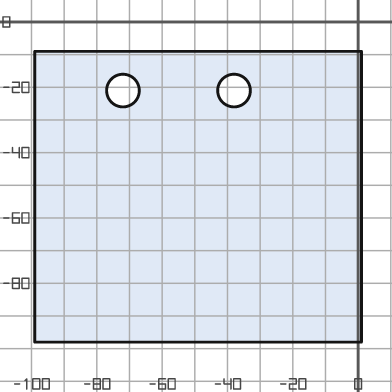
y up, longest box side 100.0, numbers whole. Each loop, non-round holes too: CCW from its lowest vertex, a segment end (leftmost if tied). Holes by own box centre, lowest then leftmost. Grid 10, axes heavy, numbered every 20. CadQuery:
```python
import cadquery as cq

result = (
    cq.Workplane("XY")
    .moveTo(-99.0, -98.0)
    .lineTo(1.0, -98.0)
    .lineTo(1.0, -9.0)
    .lineTo(-99.0, -9.0)
    .close()
    .moveTo(-72.0, -21.0)
    .circle(5.0)
    .moveTo(-38.0, -21.0)
    .circle(5.0)
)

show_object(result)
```